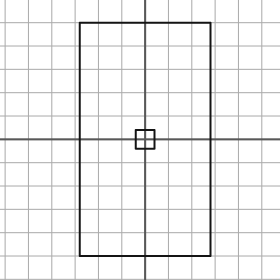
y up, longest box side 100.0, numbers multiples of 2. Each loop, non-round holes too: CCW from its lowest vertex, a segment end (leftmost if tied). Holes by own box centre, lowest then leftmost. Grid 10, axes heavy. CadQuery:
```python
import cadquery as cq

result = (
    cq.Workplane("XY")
    .moveTo(-28.0, -50.0)
    .lineTo(28.0, -50.0)
    .lineTo(28.0, 50.0)
    .lineTo(-28.0, 50.0)
    .close()
    .moveTo(-4.0, -4.0)
    .lineTo(4.0, -4.0)
    .lineTo(4.0, 4.0)
    .lineTo(-4.0, 4.0)
    .close()
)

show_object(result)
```